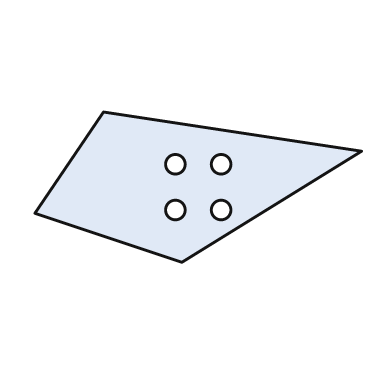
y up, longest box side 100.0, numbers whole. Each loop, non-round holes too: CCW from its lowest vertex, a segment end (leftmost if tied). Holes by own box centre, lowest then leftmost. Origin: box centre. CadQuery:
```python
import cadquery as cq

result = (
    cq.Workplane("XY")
    .moveTo(-5.0, -23.0)
    .lineTo(50.0, 11.0)
    .lineTo(-29.0, 23.0)
    .lineTo(-50.0, -8.0)
    .close()
    .moveTo(-7.0, -7.0)
    .circle(3.0)
    .moveTo(7.0, -7.0)
    .circle(3.0)
    .moveTo(-7.0, 7.0)
    .circle(3.0)
    .moveTo(7.0, 7.0)
    .circle(3.0)
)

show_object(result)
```